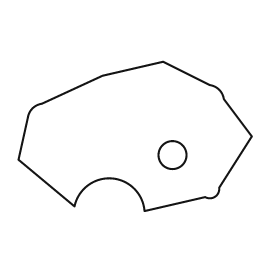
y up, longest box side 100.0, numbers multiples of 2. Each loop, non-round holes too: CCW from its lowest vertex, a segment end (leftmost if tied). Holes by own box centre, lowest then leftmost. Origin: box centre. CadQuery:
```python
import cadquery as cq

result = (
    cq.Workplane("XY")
    .moveTo(4.0, -32.0)
    .lineTo(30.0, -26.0)
    .threePointArc((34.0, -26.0), (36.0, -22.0))
    .lineTo(50.0, 0.0)
    .lineTo(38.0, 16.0)
    .threePointArc((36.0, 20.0), (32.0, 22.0))
    .lineTo(12.0, 32.0)
    .lineTo(-14.0, 26.0)
    .lineTo(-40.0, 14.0)
    .threePointArc((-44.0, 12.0), (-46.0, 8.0))
    .lineTo(-50.0, -10.0)
    .lineTo(-26.0, -30.0)
    .threePointArc((-10.0, -18.0), (4.0, -32.0))
    .close()
    .moveTo(16.0, -8.0)
    .circle(6.0)
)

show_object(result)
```